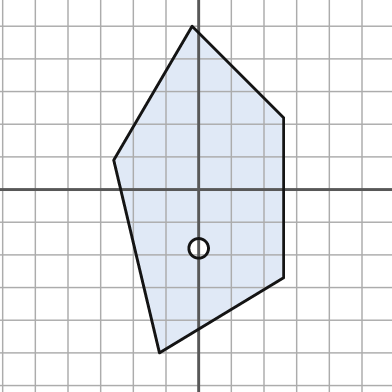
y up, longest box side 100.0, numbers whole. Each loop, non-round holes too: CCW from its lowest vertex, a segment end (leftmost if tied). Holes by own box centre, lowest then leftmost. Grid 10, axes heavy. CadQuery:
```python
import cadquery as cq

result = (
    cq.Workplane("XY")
    .moveTo(-12.0, -50.0)
    .lineTo(26.0, -27.0)
    .lineTo(26.0, 22.0)
    .lineTo(-2.0, 50.0)
    .lineTo(-26.0, 9.0)
    .close()
    .moveTo(0.0, -18.0)
    .circle(3.0)
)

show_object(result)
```